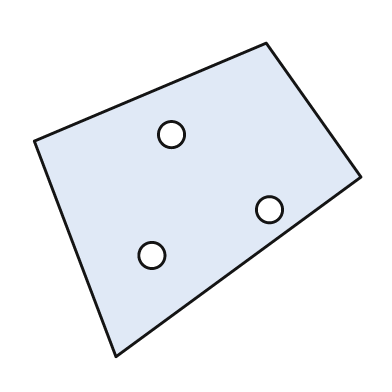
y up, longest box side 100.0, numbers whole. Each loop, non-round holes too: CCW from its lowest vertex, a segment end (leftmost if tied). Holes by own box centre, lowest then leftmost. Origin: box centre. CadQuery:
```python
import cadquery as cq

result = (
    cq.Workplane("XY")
    .moveTo(-25.0, -48.0)
    .lineTo(50.0, 7.0)
    .lineTo(21.0, 48.0)
    .lineTo(-50.0, 18.0)
    .close()
    .moveTo(-14.0, -17.0)
    .circle(4.0)
    .moveTo(22.0, -3.0)
    .circle(4.0)
    .moveTo(-8.0, 20.0)
    .circle(4.0)
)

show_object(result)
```